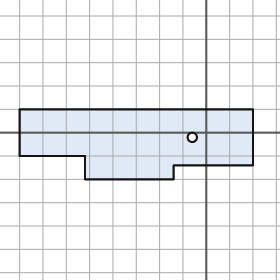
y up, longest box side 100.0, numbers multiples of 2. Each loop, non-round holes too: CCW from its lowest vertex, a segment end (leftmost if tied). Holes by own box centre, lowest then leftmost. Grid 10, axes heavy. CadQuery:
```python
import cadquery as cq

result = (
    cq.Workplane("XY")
    .moveTo(-52.0, -20.0)
    .lineTo(-14.0, -20.0)
    .lineTo(-14.0, -14.0)
    .lineTo(20.0, -14.0)
    .lineTo(20.0, 10.0)
    .lineTo(-80.0, 10.0)
    .lineTo(-80.0, -10.0)
    .lineTo(-52.0, -10.0)
    .close()
    .moveTo(-6.0, -2.0)
    .circle(2.0)
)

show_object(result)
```